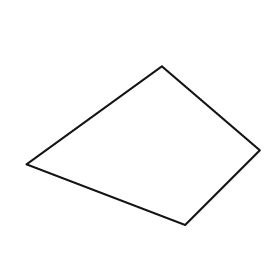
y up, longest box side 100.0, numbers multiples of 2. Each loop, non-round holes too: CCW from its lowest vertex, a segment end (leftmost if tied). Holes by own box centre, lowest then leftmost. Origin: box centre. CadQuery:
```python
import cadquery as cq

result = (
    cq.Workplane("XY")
    .moveTo(18.0, -34.0)
    .lineTo(50.0, -2.0)
    .lineTo(8.0, 34.0)
    .lineTo(-50.0, -8.0)
    .close()
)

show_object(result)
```